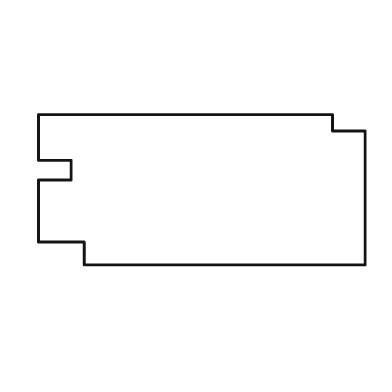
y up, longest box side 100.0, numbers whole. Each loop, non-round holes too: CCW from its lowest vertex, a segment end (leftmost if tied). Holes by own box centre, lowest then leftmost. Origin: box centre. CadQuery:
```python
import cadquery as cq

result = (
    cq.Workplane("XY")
    .moveTo(-36.0, -23.0)
    .lineTo(50.0, -23.0)
    .lineTo(50.0, 18.0)
    .lineTo(40.0, 18.0)
    .lineTo(40.0, 23.0)
    .lineTo(-50.0, 23.0)
    .lineTo(-50.0, 9.0)
    .lineTo(-40.0, 9.0)
    .lineTo(-40.0, 3.0)
    .lineTo(-50.0, 3.0)
    .lineTo(-50.0, -16.0)
    .lineTo(-36.0, -16.0)
    .close()
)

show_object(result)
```